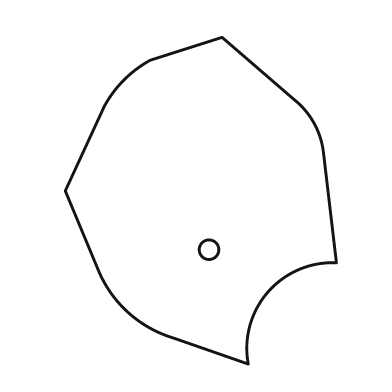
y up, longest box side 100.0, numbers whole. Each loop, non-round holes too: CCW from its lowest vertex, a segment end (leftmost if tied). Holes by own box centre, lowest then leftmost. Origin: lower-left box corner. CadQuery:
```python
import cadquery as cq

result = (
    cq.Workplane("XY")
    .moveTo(56.0, 0.0)
    .threePointArc((62.0, 22.0), (83.0, 31.0))
    .lineTo(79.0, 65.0)
    .threePointArc((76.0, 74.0), (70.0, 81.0))
    .lineTo(48.0, 100.0)
    .lineTo(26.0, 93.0)
    .threePointArc((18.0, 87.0), (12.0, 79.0))
    .lineTo(0.0, 53.0)
    .lineTo(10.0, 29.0)
    .threePointArc((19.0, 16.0), (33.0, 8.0))
    .close()
    .moveTo(44.0, 35.0)
    .circle(3.0)
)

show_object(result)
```